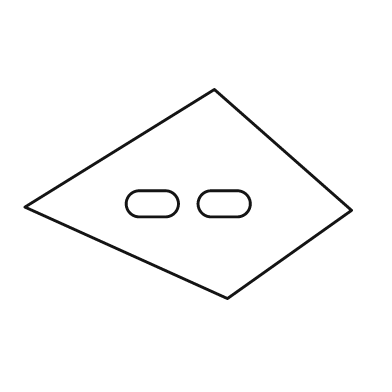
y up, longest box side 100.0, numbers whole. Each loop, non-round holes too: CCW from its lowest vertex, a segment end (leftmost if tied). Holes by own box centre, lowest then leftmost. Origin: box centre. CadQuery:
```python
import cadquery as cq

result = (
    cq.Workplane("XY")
    .moveTo(12.0, -32.0)
    .lineTo(50.0, -5.0)
    .lineTo(8.0, 32.0)
    .lineTo(-50.0, -4.0)
    .close()
    .moveTo(-15.0, -7.0)
    .lineTo(-7.0, -7.0)
    .threePointArc((-3.0, -3.0), (-7.0, 1.0))
    .lineTo(-15.0, 1.0)
    .threePointArc((-19.0, -3.0), (-15.0, -7.0))
    .close()
    .moveTo(7.0, -7.0)
    .lineTo(15.0, -7.0)
    .threePointArc((19.0, -3.0), (15.0, 1.0))
    .lineTo(7.0, 1.0)
    .threePointArc((3.0, -3.0), (7.0, -7.0))
    .close()
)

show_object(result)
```